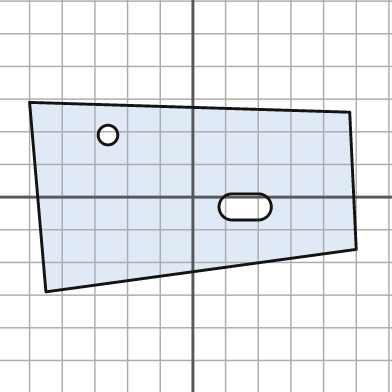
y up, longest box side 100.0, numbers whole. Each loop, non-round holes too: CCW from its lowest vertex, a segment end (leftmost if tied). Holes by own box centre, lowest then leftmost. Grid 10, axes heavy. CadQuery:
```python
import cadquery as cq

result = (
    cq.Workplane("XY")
    .moveTo(-45.0, -29.0)
    .lineTo(50.0, -16.0)
    .lineTo(48.0, 26.0)
    .lineTo(-50.0, 29.0)
    .close()
    .moveTo(12.0, -7.0)
    .lineTo(20.0, -7.0)
    .threePointArc((24.0, -3.0), (20.0, 1.0))
    .lineTo(12.0, 1.0)
    .threePointArc((8.0, -3.0), (12.0, -7.0))
    .close()
    .moveTo(-26.0, 19.0)
    .circle(3.0)
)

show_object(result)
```